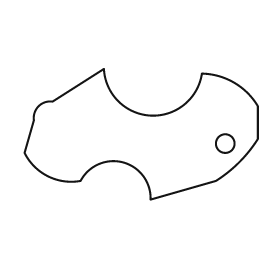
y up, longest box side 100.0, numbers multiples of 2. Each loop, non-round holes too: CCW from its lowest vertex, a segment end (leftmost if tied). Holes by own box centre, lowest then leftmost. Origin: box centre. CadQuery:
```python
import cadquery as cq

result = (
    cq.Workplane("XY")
    .moveTo(4.0, -28.0)
    .lineTo(32.0, -20.0)
    .threePointArc((42.0, -12.0), (50.0, -2.0))
    .lineTo(50.0, 12.0)
    .threePointArc((40.0, 22.0), (26.0, 26.0))
    .threePointArc((4.0, 8.0), (-16.0, 28.0))
    .lineTo(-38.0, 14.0)
    .threePointArc((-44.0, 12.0), (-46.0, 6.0))
    .lineTo(-50.0, -8.0)
    .threePointArc((-40.0, -18.0), (-26.0, -20.0))
    .threePointArc((-8.0, -12.0), (4.0, -28.0))
    .close()
    .moveTo(36.0, -4.0)
    .circle(4.0)
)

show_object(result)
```